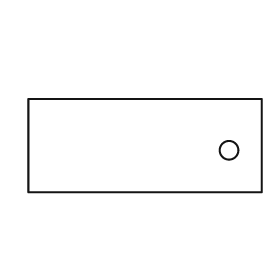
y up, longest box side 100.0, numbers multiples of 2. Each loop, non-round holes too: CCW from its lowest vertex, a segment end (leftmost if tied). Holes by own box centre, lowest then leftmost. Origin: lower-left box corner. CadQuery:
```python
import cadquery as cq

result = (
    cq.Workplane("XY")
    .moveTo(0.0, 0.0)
    .lineTo(100.0, 0.0)
    .lineTo(100.0, 40.0)
    .lineTo(0.0, 40.0)
    .close()
    .moveTo(86.0, 18.0)
    .circle(4.0)
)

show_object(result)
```